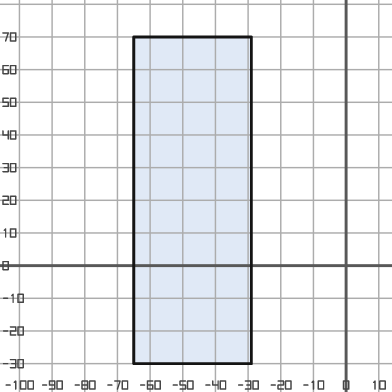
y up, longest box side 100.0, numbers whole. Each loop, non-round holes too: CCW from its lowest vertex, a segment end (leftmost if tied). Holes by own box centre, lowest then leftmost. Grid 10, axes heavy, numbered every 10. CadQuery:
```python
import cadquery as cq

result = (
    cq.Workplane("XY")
    .moveTo(-65.0, -30.0)
    .lineTo(-29.0, -30.0)
    .lineTo(-29.0, 70.0)
    .lineTo(-65.0, 70.0)
    .close()
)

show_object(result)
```